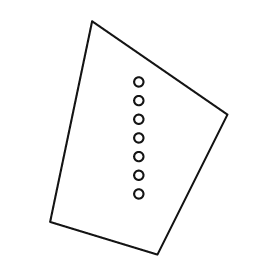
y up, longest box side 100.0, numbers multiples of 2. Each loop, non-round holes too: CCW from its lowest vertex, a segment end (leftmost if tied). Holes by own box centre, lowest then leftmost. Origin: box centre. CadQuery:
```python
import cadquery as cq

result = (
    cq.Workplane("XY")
    .moveTo(8.0, -50.0)
    .lineTo(38.0, 10.0)
    .lineTo(-20.0, 50.0)
    .lineTo(-38.0, -36.0)
    .close()
    .moveTo(0.0, -24.0)
    .circle(2.0)
    .moveTo(0.0, -16.0)
    .circle(2.0)
    .moveTo(0.0, -8.0)
    .circle(2.0)
    .moveTo(0.0, 0.0)
    .circle(2.0)
    .moveTo(0.0, 8.0)
    .circle(2.0)
    .moveTo(0.0, 16.0)
    .circle(2.0)
    .moveTo(0.0, 24.0)
    .circle(2.0)
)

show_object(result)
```